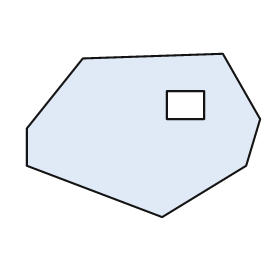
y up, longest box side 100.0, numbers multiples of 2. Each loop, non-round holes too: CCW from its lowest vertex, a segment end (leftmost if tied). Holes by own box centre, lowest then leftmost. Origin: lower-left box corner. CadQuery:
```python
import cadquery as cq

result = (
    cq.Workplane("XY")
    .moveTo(58.0, 0.0)
    .lineTo(94.0, 22.0)
    .lineTo(100.0, 42.0)
    .lineTo(84.0, 70.0)
    .lineTo(24.0, 68.0)
    .lineTo(0.0, 38.0)
    .lineTo(0.0, 22.0)
    .close()
    .moveTo(60.0, 42.0)
    .lineTo(76.0, 42.0)
    .lineTo(76.0, 54.0)
    .lineTo(60.0, 54.0)
    .close()
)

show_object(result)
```